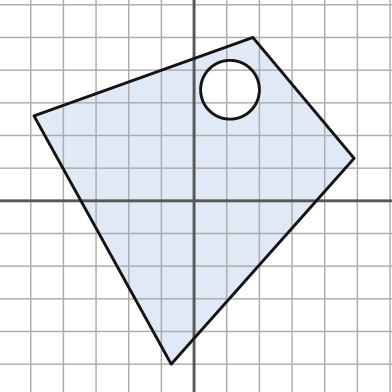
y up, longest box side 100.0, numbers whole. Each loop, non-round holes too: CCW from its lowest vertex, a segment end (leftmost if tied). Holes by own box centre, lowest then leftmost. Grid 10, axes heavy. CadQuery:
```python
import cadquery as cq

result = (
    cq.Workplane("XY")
    .moveTo(-7.0, -50.0)
    .lineTo(49.0, 13.0)
    .lineTo(18.0, 50.0)
    .lineTo(-49.0, 26.0)
    .close()
    .moveTo(11.0, 34.0)
    .circle(9.0)
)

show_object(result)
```